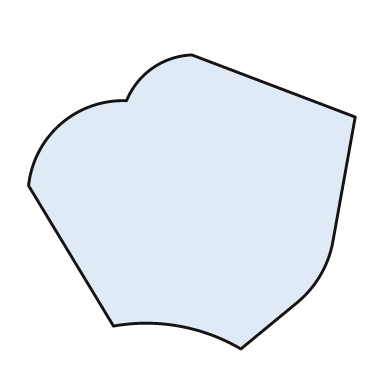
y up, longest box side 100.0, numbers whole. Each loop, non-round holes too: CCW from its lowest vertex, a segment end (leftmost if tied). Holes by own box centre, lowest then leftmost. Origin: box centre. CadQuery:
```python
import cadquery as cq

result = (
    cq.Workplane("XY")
    .moveTo(15.0, -45.0)
    .lineTo(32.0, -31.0)
    .threePointArc((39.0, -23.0), (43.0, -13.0))
    .lineTo(50.0, 26.0)
    .lineTo(0.0, 45.0)
    .threePointArc((-12.0, 41.0), (-20.0, 31.0))
    .threePointArc((-40.0, 24.0), (-50.0, 5.0))
    .lineTo(-24.0, -38.0)
    .threePointArc((-4.0, -38.0), (15.0, -45.0))
    .close()
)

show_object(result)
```